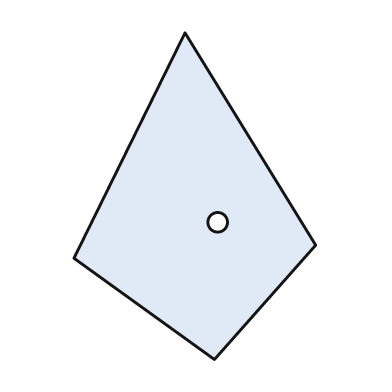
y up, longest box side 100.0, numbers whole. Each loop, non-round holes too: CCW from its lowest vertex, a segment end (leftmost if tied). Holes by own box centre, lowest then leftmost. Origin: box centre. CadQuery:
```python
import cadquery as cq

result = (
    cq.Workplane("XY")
    .moveTo(6.0, -50.0)
    .lineTo(37.0, -15.0)
    .lineTo(-3.0, 50.0)
    .lineTo(-37.0, -19.0)
    .close()
    .moveTo(7.0, -8.0)
    .circle(3.0)
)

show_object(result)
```